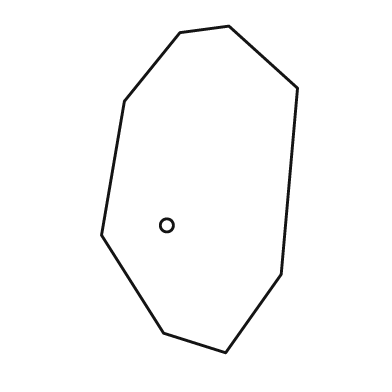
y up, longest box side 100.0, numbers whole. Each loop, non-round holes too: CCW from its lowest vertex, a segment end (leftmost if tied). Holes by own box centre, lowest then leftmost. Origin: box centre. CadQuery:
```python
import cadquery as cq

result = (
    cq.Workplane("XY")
    .moveTo(8.0, -50.0)
    .lineTo(25.0, -26.0)
    .lineTo(30.0, 31.0)
    .lineTo(9.0, 50.0)
    .lineTo(-6.0, 48.0)
    .lineTo(-23.0, 27.0)
    .lineTo(-30.0, -14.0)
    .lineTo(-11.0, -44.0)
    .close()
    .moveTo(-10.0, -11.0)
    .circle(2.0)
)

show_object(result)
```